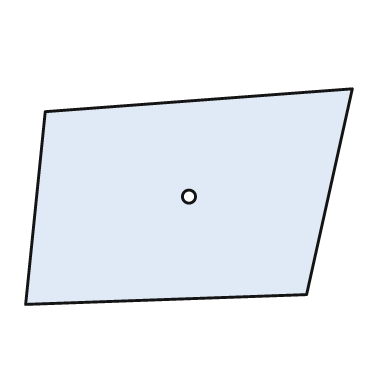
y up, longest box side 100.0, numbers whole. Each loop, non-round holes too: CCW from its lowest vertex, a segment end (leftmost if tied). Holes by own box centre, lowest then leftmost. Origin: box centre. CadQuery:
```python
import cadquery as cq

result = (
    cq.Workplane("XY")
    .moveTo(-50.0, -33.0)
    .lineTo(36.0, -30.0)
    .lineTo(50.0, 33.0)
    .lineTo(-44.0, 26.0)
    .close()
    .moveTo(0.0, 0.0)
    .circle(2.0)
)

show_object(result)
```